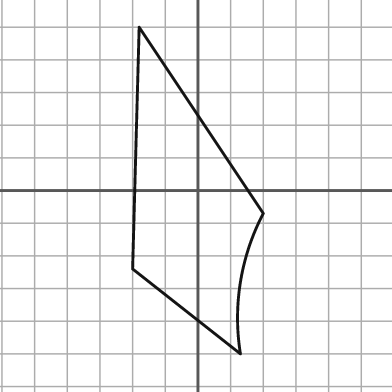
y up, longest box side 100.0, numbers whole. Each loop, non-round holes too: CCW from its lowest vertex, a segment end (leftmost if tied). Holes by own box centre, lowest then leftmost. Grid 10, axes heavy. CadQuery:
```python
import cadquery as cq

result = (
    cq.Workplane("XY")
    .moveTo(13.0, -50.0)
    .threePointArc((13.0, -28.0), (20.0, -7.0))
    .lineTo(-18.0, 50.0)
    .lineTo(-20.0, -24.0)
    .close()
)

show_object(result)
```